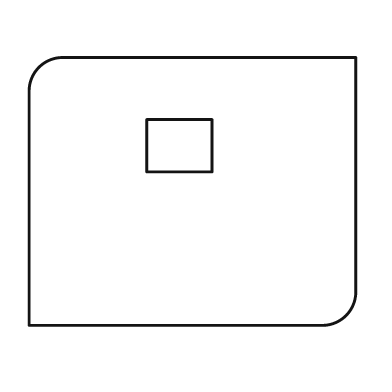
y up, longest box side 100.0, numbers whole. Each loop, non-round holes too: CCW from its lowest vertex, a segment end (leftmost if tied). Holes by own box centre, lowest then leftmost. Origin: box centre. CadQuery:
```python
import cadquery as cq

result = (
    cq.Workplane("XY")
    .moveTo(-50.0, -41.0)
    .lineTo(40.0, -41.0)
    .threePointArc((47.0, -38.0), (50.0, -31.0))
    .lineTo(50.0, 41.0)
    .lineTo(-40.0, 41.0)
    .threePointArc((-47.0, 38.0), (-50.0, 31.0))
    .close()
    .moveTo(-14.0, 6.0)
    .lineTo(6.0, 6.0)
    .lineTo(6.0, 22.0)
    .lineTo(-14.0, 22.0)
    .close()
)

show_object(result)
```